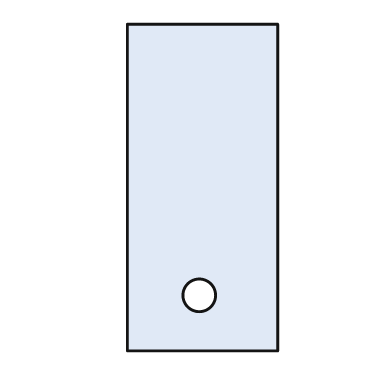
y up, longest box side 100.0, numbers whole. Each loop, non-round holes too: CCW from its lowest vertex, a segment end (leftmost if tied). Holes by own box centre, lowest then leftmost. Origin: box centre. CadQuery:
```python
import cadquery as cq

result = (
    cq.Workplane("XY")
    .moveTo(-23.0, -50.0)
    .lineTo(23.0, -50.0)
    .lineTo(23.0, 50.0)
    .lineTo(-23.0, 50.0)
    .close()
    .moveTo(-1.0, -33.0)
    .circle(5.0)
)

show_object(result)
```